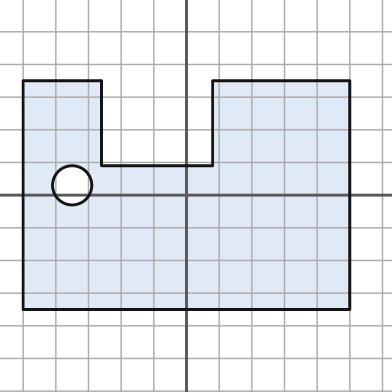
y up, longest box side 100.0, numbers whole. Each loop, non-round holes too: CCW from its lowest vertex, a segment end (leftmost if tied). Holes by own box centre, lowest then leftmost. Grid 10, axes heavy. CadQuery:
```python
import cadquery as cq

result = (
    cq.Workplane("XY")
    .moveTo(-50.0, -35.0)
    .lineTo(50.0, -35.0)
    .lineTo(50.0, 35.0)
    .lineTo(8.0, 35.0)
    .lineTo(8.0, 9.0)
    .lineTo(-26.0, 9.0)
    .lineTo(-26.0, 35.0)
    .lineTo(-50.0, 35.0)
    .close()
    .moveTo(-35.0, 3.0)
    .circle(6.0)
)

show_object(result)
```